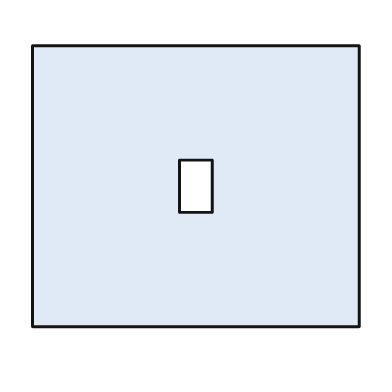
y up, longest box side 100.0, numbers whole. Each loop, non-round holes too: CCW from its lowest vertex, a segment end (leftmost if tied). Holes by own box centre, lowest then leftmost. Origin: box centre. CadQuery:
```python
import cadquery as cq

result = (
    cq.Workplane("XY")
    .moveTo(-50.0, -43.0)
    .lineTo(50.0, -43.0)
    .lineTo(50.0, 43.0)
    .lineTo(-50.0, 43.0)
    .close()
    .moveTo(-5.0, -8.0)
    .lineTo(5.0, -8.0)
    .lineTo(5.0, 8.0)
    .lineTo(-5.0, 8.0)
    .close()
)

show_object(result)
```